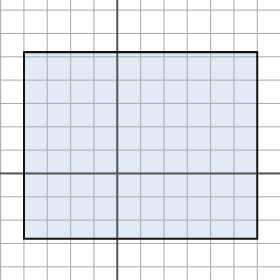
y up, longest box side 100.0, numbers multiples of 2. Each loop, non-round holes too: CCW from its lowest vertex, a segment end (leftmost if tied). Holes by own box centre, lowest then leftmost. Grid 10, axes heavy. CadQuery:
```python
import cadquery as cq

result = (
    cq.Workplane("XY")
    .moveTo(-40.0, -28.0)
    .lineTo(60.0, -28.0)
    .lineTo(60.0, 52.0)
    .lineTo(-40.0, 52.0)
    .close()
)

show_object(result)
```